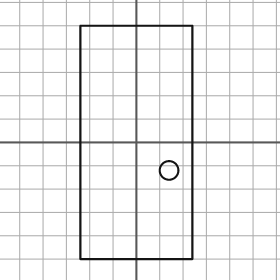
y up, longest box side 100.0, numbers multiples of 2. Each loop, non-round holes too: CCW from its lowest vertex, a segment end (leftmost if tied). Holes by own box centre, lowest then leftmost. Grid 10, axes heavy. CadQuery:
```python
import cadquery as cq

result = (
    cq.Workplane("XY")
    .moveTo(-24.0, -50.0)
    .lineTo(24.0, -50.0)
    .lineTo(24.0, 50.0)
    .lineTo(-24.0, 50.0)
    .close()
    .moveTo(14.0, -12.0)
    .circle(4.0)
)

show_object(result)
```